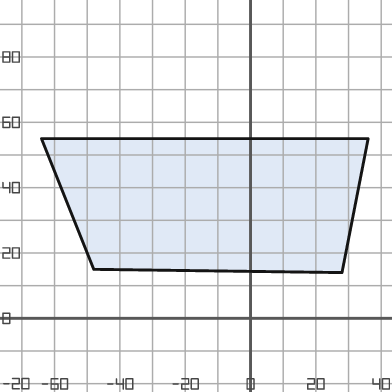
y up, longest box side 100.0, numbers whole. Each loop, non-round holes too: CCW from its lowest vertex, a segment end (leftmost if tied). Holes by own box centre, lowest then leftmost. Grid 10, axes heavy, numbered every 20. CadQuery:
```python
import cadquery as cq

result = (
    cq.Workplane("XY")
    .moveTo(28.0, 14.0)
    .lineTo(36.0, 55.0)
    .lineTo(-64.0, 55.0)
    .lineTo(-48.0, 15.0)
    .close()
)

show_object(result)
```